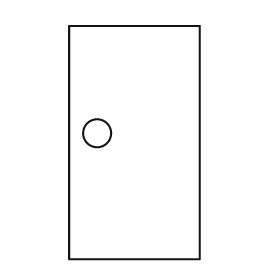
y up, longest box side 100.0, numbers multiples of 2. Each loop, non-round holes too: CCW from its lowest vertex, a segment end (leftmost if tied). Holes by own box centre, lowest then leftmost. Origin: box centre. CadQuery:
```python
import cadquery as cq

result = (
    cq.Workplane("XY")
    .moveTo(-28.0, -50.0)
    .lineTo(28.0, -50.0)
    .lineTo(28.0, 50.0)
    .lineTo(-28.0, 50.0)
    .close()
    .moveTo(-16.0, 4.0)
    .circle(6.0)
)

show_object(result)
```